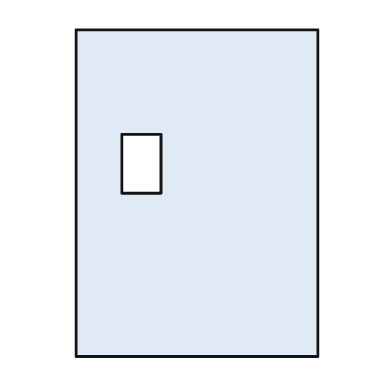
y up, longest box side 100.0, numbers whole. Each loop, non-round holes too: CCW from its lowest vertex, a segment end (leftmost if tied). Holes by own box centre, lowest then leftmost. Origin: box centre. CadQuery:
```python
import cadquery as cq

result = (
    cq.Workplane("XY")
    .moveTo(-37.0, -50.0)
    .lineTo(37.0, -50.0)
    .lineTo(37.0, 50.0)
    .lineTo(-37.0, 50.0)
    .close()
    .moveTo(-23.0, 0.0)
    .lineTo(-11.0, 0.0)
    .lineTo(-11.0, 18.0)
    .lineTo(-23.0, 18.0)
    .close()
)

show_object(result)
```